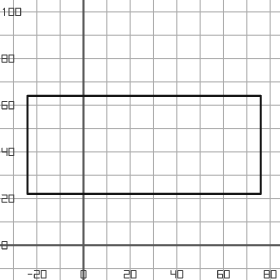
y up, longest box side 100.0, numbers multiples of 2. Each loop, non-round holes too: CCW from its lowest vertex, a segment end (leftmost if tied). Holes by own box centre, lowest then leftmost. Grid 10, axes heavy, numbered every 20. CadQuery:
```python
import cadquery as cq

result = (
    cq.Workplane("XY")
    .moveTo(-24.0, 22.0)
    .lineTo(76.0, 22.0)
    .lineTo(76.0, 64.0)
    .lineTo(-24.0, 64.0)
    .close()
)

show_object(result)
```